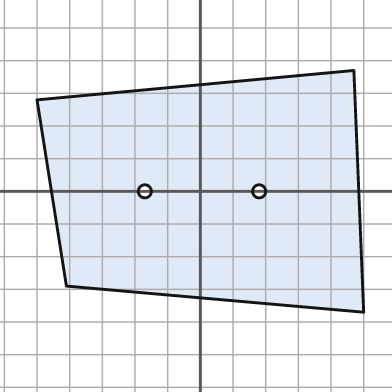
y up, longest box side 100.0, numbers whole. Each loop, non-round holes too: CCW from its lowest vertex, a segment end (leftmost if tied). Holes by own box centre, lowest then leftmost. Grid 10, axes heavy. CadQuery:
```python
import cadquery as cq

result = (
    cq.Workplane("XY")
    .moveTo(50.0, -37.0)
    .lineTo(47.0, 37.0)
    .lineTo(-50.0, 28.0)
    .lineTo(-41.0, -29.0)
    .close()
    .moveTo(-17.0, 0.0)
    .circle(2.0)
    .moveTo(18.0, 0.0)
    .circle(2.0)
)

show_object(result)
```